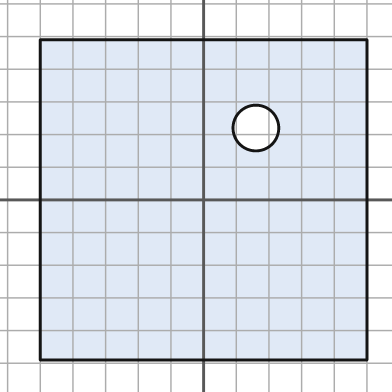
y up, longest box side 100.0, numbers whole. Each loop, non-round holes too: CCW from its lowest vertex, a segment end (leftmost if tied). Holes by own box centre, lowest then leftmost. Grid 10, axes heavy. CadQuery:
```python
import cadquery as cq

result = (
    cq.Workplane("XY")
    .moveTo(-50.0, -49.0)
    .lineTo(50.0, -49.0)
    .lineTo(50.0, 49.0)
    .lineTo(-50.0, 49.0)
    .close()
    .moveTo(16.0, 22.0)
    .circle(7.0)
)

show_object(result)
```